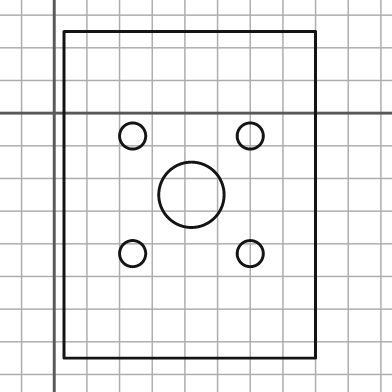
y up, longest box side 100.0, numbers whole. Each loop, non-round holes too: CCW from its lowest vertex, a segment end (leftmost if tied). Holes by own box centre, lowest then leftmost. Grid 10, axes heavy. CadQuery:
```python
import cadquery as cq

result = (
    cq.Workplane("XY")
    .moveTo(3.0, -75.0)
    .lineTo(80.0, -75.0)
    .lineTo(80.0, 25.0)
    .lineTo(3.0, 25.0)
    .close()
    .moveTo(24.0, -43.0)
    .circle(4.0)
    .moveTo(60.0, -43.0)
    .circle(4.0)
    .moveTo(42.0, -25.0)
    .circle(10.0)
    .moveTo(24.0, -7.0)
    .circle(4.0)
    .moveTo(60.0, -7.0)
    .circle(4.0)
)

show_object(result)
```